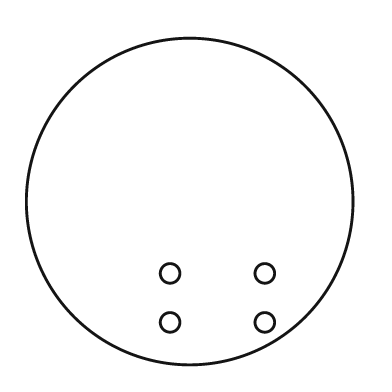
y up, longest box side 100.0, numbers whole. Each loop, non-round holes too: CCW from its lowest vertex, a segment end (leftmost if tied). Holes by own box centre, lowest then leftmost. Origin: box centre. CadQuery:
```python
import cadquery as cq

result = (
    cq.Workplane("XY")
    .moveTo(0.0, 0.0)
    .circle(50.0)
    .moveTo(-6.0, -37.0)
    .circle(3.0)
    .moveTo(23.0, -37.0)
    .circle(3.0)
    .moveTo(-6.0, -22.0)
    .circle(3.0)
    .moveTo(23.0, -22.0)
    .circle(3.0)
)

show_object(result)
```